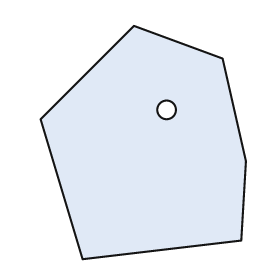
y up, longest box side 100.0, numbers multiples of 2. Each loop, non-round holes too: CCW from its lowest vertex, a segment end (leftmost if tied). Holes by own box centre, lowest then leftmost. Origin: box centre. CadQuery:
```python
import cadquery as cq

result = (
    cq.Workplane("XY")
    .moveTo(-26.0, -50.0)
    .lineTo(42.0, -42.0)
    .lineTo(44.0, -8.0)
    .lineTo(34.0, 36.0)
    .lineTo(-4.0, 50.0)
    .lineTo(-44.0, 10.0)
    .close()
    .moveTo(10.0, 14.0)
    .circle(4.0)
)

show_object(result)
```